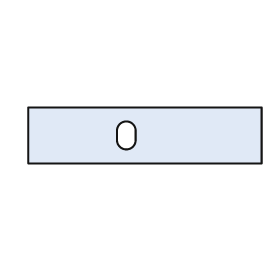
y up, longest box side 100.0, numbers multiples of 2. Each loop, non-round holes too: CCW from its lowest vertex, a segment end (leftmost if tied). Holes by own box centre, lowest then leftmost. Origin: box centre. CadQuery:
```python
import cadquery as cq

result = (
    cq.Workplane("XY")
    .moveTo(-50.0, -12.0)
    .lineTo(50.0, -12.0)
    .lineTo(50.0, 12.0)
    .lineTo(-50.0, 12.0)
    .close()
    .moveTo(-12.0, -2.0)
    .threePointArc((-8.0, -6.0), (-4.0, -2.0))
    .lineTo(-4.0, 2.0)
    .threePointArc((-8.0, 6.0), (-12.0, 2.0))
    .close()
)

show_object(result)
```